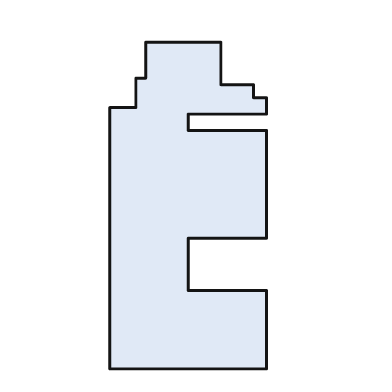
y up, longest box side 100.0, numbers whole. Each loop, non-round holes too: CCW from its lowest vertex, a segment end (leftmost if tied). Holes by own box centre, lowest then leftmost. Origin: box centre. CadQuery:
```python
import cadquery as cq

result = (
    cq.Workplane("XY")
    .moveTo(-24.0, -50.0)
    .lineTo(24.0, -50.0)
    .lineTo(24.0, -26.0)
    .lineTo(0.0, -26.0)
    .lineTo(0.0, -10.0)
    .lineTo(24.0, -10.0)
    .lineTo(24.0, 23.0)
    .lineTo(0.0, 23.0)
    .lineTo(0.0, 28.0)
    .lineTo(24.0, 28.0)
    .lineTo(24.0, 33.0)
    .lineTo(20.0, 33.0)
    .lineTo(20.0, 37.0)
    .lineTo(10.0, 37.0)
    .lineTo(10.0, 50.0)
    .lineTo(-13.0, 50.0)
    .lineTo(-13.0, 39.0)
    .lineTo(-16.0, 39.0)
    .lineTo(-16.0, 30.0)
    .lineTo(-24.0, 30.0)
    .close()
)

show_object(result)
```